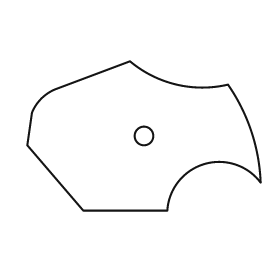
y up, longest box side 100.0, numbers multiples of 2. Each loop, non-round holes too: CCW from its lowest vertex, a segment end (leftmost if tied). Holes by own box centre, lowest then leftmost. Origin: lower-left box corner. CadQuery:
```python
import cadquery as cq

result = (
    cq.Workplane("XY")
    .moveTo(24.0, 0.0)
    .lineTo(60.0, 0.0)
    .threePointArc((76.0, 20.0), (100.0, 12.0))
    .threePointArc((96.0, 34.0), (86.0, 54.0))
    .threePointArc((64.0, 54.0), (44.0, 64.0))
    .lineTo(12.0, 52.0)
    .threePointArc((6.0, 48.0), (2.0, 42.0))
    .lineTo(0.0, 28.0)
    .close()
    .moveTo(50.0, 32.0)
    .circle(4.0)
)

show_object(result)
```